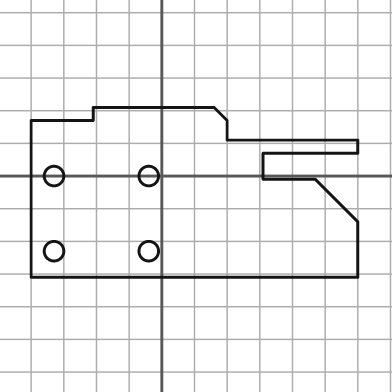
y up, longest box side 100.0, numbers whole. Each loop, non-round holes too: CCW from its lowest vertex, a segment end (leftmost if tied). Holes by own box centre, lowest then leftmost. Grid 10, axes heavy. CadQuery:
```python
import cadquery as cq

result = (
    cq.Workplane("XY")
    .moveTo(-40.0, -31.0)
    .lineTo(60.0, -31.0)
    .lineTo(60.0, -14.0)
    .lineTo(47.0, -1.0)
    .lineTo(31.0, -1.0)
    .lineTo(31.0, 7.0)
    .lineTo(60.0, 7.0)
    .lineTo(60.0, 11.0)
    .lineTo(20.0, 11.0)
    .lineTo(20.0, 17.0)
    .lineTo(16.0, 21.0)
    .lineTo(-21.0, 21.0)
    .lineTo(-21.0, 17.0)
    .lineTo(-40.0, 17.0)
    .close()
    .moveTo(-33.0, -23.0)
    .circle(3.0)
    .moveTo(-4.0, -23.0)
    .circle(3.0)
    .moveTo(-33.0, 0.0)
    .circle(3.0)
    .moveTo(-4.0, 0.0)
    .circle(3.0)
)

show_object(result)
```